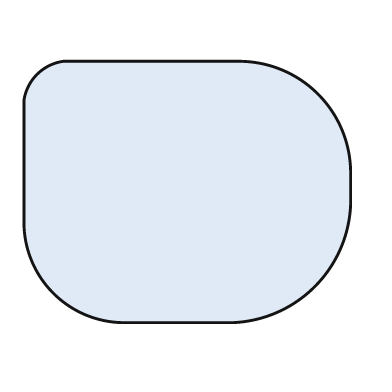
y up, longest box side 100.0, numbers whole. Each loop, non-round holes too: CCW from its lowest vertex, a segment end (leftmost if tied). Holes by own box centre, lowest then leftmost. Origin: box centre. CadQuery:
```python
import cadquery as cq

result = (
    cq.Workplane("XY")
    .moveTo(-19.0, -40.0)
    .lineTo(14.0, -40.0)
    .threePointArc((39.0, -29.0), (50.0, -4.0))
    .lineTo(50.0, 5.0)
    .threePointArc((40.0, 30.0), (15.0, 40.0))
    .lineTo(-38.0, 40.0)
    .threePointArc((-46.0, 36.0), (-50.0, 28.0))
    .lineTo(-50.0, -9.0)
    .threePointArc((-41.0, -31.0), (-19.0, -40.0))
    .close()
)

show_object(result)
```